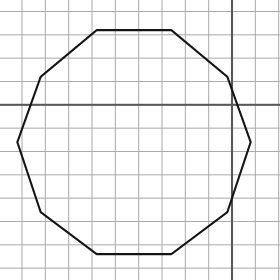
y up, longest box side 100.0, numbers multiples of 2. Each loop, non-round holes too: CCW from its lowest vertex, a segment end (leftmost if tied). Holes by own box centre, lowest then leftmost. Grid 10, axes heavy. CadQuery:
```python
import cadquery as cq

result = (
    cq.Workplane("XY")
    .moveTo(-58.0, -64.0)
    .lineTo(-26.0, -64.0)
    .lineTo(-2.0, -46.0)
    .lineTo(8.0, -16.0)
    .lineTo(-2.0, 12.0)
    .lineTo(-26.0, 32.0)
    .lineTo(-58.0, 32.0)
    .lineTo(-82.0, 12.0)
    .lineTo(-92.0, -16.0)
    .lineTo(-82.0, -46.0)
    .close()
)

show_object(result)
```